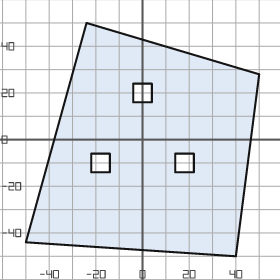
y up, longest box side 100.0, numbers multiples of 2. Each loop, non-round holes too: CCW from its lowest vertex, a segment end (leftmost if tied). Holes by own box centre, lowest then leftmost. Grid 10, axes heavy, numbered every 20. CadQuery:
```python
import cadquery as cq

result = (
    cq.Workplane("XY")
    .moveTo(40.0, -50.0)
    .lineTo(50.0, 28.0)
    .lineTo(-24.0, 50.0)
    .lineTo(-50.0, -44.0)
    .close()
    .moveTo(-22.0, -14.0)
    .lineTo(-14.0, -14.0)
    .lineTo(-14.0, -6.0)
    .lineTo(-22.0, -6.0)
    .close()
    .moveTo(14.0, -14.0)
    .lineTo(22.0, -14.0)
    .lineTo(22.0, -6.0)
    .lineTo(14.0, -6.0)
    .close()
    .moveTo(-4.0, 16.0)
    .lineTo(4.0, 16.0)
    .lineTo(4.0, 24.0)
    .lineTo(-4.0, 24.0)
    .close()
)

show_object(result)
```